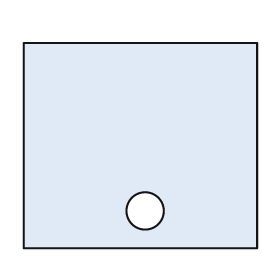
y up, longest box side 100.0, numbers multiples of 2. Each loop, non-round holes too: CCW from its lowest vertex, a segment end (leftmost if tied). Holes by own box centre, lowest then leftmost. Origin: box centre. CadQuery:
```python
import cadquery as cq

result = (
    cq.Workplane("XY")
    .moveTo(-50.0, -44.0)
    .lineTo(50.0, -44.0)
    .lineTo(50.0, 44.0)
    .lineTo(-50.0, 44.0)
    .close()
    .moveTo(2.0, -28.0)
    .circle(8.0)
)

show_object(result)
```